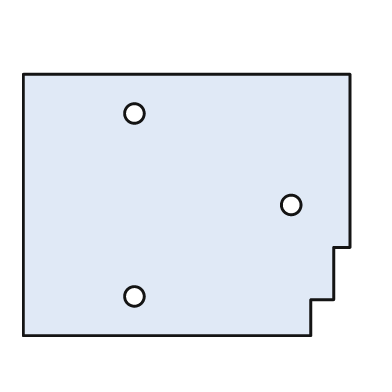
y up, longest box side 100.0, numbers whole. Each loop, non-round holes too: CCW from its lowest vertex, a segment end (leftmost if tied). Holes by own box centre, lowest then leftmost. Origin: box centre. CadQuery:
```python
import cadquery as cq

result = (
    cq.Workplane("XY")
    .moveTo(-50.0, -40.0)
    .lineTo(38.0, -40.0)
    .lineTo(38.0, -29.0)
    .lineTo(45.0, -29.0)
    .lineTo(45.0, -13.0)
    .lineTo(50.0, -13.0)
    .lineTo(50.0, 40.0)
    .lineTo(-50.0, 40.0)
    .close()
    .moveTo(-16.0, -28.0)
    .circle(3.0)
    .moveTo(32.0, 0.0)
    .circle(3.0)
    .moveTo(-16.0, 28.0)
    .circle(3.0)
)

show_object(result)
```